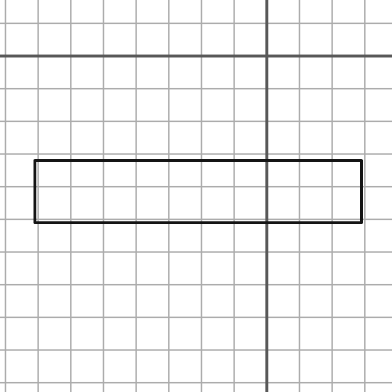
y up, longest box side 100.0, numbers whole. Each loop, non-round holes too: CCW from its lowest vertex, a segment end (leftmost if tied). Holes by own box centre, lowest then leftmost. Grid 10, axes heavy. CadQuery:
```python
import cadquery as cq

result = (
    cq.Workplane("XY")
    .moveTo(-71.0, -51.0)
    .lineTo(29.0, -51.0)
    .lineTo(29.0, -32.0)
    .lineTo(-71.0, -32.0)
    .close()
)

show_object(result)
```